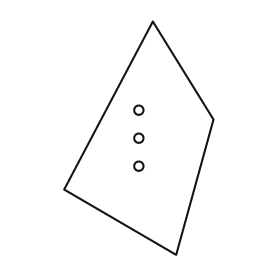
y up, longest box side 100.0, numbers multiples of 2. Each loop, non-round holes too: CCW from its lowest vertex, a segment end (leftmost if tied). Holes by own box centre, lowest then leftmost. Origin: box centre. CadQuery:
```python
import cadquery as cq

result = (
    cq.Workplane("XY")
    .moveTo(16.0, -50.0)
    .lineTo(32.0, 8.0)
    .lineTo(6.0, 50.0)
    .lineTo(-32.0, -22.0)
    .close()
    .moveTo(0.0, -12.0)
    .circle(2.0)
    .moveTo(0.0, 0.0)
    .circle(2.0)
    .moveTo(0.0, 12.0)
    .circle(2.0)
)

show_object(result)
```